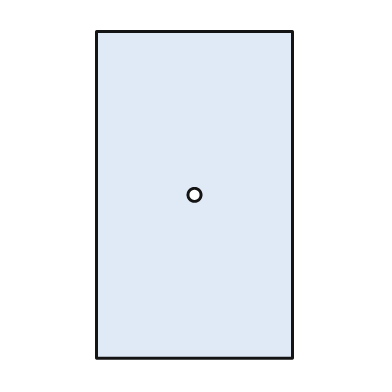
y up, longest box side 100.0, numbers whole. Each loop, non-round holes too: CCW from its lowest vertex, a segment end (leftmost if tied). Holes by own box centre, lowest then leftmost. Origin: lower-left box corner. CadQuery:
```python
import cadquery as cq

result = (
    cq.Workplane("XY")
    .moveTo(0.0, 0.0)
    .lineTo(60.0, 0.0)
    .lineTo(60.0, 100.0)
    .lineTo(0.0, 100.0)
    .close()
    .moveTo(30.0, 50.0)
    .circle(2.0)
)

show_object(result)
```